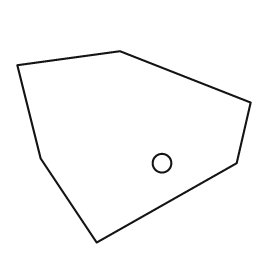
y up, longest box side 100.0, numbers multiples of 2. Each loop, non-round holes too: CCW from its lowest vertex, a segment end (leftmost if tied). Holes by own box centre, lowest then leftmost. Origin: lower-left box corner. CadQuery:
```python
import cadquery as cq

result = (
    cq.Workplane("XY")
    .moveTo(34.0, 0.0)
    .lineTo(94.0, 34.0)
    .lineTo(100.0, 60.0)
    .lineTo(44.0, 82.0)
    .lineTo(0.0, 76.0)
    .lineTo(10.0, 36.0)
    .close()
    .moveTo(62.0, 34.0)
    .circle(4.0)
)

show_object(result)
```